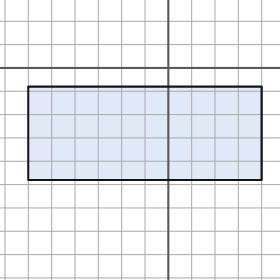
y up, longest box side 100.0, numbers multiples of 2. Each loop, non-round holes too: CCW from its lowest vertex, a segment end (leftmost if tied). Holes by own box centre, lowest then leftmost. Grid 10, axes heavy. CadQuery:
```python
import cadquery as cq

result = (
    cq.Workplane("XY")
    .moveTo(-60.0, -48.0)
    .lineTo(40.0, -48.0)
    .lineTo(40.0, -8.0)
    .lineTo(-60.0, -8.0)
    .close()
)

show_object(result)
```